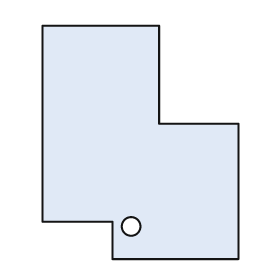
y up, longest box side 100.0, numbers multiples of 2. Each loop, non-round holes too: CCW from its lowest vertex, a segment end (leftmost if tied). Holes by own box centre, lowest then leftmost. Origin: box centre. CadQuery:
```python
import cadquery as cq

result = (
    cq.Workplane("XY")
    .moveTo(-12.0, -50.0)
    .lineTo(42.0, -50.0)
    .lineTo(42.0, 8.0)
    .lineTo(8.0, 8.0)
    .lineTo(8.0, 50.0)
    .lineTo(-42.0, 50.0)
    .lineTo(-42.0, -34.0)
    .lineTo(-12.0, -34.0)
    .close()
    .moveTo(-4.0, -36.0)
    .circle(4.0)
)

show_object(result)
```